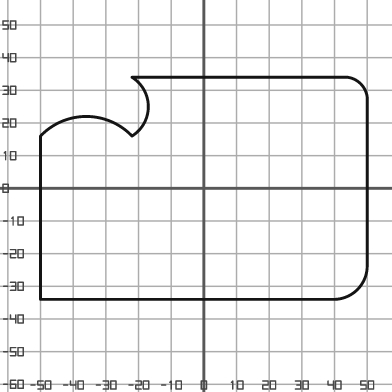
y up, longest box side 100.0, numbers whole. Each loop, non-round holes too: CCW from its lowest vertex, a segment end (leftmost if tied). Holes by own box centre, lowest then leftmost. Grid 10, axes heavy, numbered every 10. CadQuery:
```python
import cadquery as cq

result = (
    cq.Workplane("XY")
    .moveTo(-50.0, -34.0)
    .lineTo(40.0, -34.0)
    .threePointArc((47.0, -31.0), (50.0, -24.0))
    .lineTo(50.0, 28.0)
    .threePointArc((48.0, 32.0), (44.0, 34.0))
    .lineTo(-22.0, 34.0)
    .threePointArc((-17.0, 25.0), (-22.0, 16.0))
    .threePointArc((-36.0, 22.0), (-50.0, 16.0))
    .close()
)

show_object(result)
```